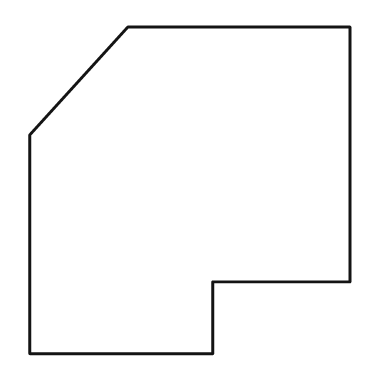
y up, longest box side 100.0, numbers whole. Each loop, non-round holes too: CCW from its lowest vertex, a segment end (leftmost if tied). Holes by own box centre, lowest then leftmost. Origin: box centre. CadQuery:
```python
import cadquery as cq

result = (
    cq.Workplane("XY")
    .moveTo(-49.0, -50.0)
    .lineTo(7.0, -50.0)
    .lineTo(7.0, -28.0)
    .lineTo(49.0, -28.0)
    .lineTo(49.0, 50.0)
    .lineTo(-19.0, 50.0)
    .lineTo(-49.0, 17.0)
    .close()
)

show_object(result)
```